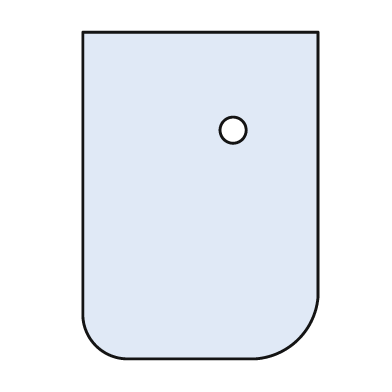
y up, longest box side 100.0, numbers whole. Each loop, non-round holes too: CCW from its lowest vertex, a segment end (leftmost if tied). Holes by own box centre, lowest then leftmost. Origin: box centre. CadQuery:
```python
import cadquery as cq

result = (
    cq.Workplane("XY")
    .moveTo(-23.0, -50.0)
    .lineTo(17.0, -50.0)
    .threePointArc((30.0, -44.0), (36.0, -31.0))
    .lineTo(36.0, 50.0)
    .lineTo(-36.0, 50.0)
    .lineTo(-36.0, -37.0)
    .threePointArc((-32.0, -46.0), (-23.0, -50.0))
    .close()
    .moveTo(10.0, 20.0)
    .circle(4.0)
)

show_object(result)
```